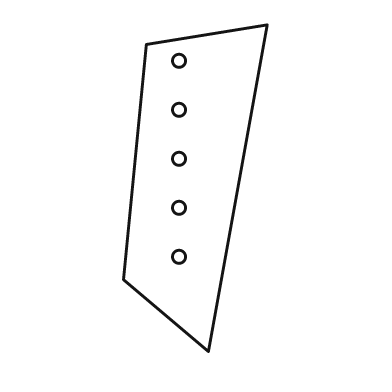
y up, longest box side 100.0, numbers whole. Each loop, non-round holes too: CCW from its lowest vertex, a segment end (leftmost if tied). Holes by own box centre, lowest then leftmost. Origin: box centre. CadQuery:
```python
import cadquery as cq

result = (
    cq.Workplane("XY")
    .moveTo(4.0, -50.0)
    .lineTo(22.0, 50.0)
    .lineTo(-15.0, 44.0)
    .lineTo(-22.0, -28.0)
    .close()
    .moveTo(-5.0, -21.0)
    .circle(2.0)
    .moveTo(-5.0, -6.0)
    .circle(2.0)
    .moveTo(-5.0, 9.0)
    .circle(2.0)
    .moveTo(-5.0, 24.0)
    .circle(2.0)
    .moveTo(-5.0, 39.0)
    .circle(2.0)
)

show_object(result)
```